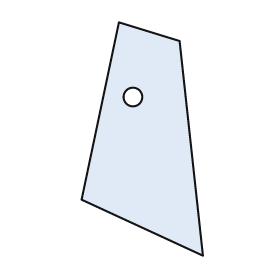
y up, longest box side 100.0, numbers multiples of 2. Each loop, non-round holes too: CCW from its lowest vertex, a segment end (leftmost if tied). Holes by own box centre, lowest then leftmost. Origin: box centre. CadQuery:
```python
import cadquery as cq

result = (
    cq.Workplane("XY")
    .moveTo(26.0, -50.0)
    .lineTo(16.0, 42.0)
    .lineTo(-10.0, 50.0)
    .lineTo(-26.0, -26.0)
    .close()
    .moveTo(-4.0, 18.0)
    .circle(4.0)
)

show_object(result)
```